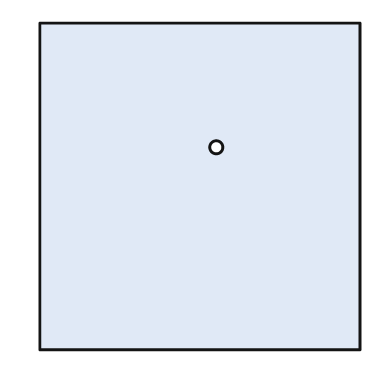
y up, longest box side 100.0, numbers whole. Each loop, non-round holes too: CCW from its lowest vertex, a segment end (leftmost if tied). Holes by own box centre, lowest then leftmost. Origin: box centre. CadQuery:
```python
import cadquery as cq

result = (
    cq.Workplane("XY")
    .moveTo(-49.0, -50.0)
    .lineTo(49.0, -50.0)
    .lineTo(49.0, 50.0)
    .lineTo(-49.0, 50.0)
    .close()
    .moveTo(5.0, 12.0)
    .circle(2.0)
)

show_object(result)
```